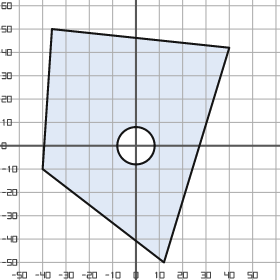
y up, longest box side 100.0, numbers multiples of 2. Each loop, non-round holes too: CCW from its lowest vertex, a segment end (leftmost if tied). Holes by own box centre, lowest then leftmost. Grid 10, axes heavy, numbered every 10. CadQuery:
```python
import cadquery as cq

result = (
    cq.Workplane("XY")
    .moveTo(12.0, -50.0)
    .lineTo(40.0, 42.0)
    .lineTo(-36.0, 50.0)
    .lineTo(-40.0, -10.0)
    .close()
    .moveTo(0.0, 0.0)
    .circle(8.0)
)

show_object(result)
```